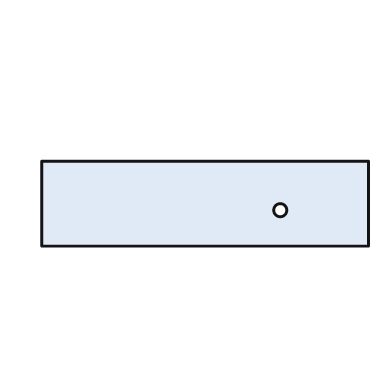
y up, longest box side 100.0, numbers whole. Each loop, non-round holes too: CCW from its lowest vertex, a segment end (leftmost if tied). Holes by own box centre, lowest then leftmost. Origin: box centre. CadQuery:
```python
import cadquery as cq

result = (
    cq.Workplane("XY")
    .moveTo(-50.0, -13.0)
    .lineTo(50.0, -13.0)
    .lineTo(50.0, 13.0)
    .lineTo(-50.0, 13.0)
    .close()
    .moveTo(23.0, -2.0)
    .circle(2.0)
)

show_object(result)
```